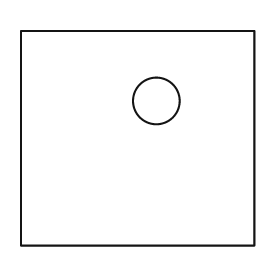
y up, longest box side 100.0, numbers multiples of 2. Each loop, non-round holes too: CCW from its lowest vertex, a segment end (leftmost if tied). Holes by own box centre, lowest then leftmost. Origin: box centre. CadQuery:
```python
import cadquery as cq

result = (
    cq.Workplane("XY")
    .moveTo(-50.0, -46.0)
    .lineTo(50.0, -46.0)
    .lineTo(50.0, 46.0)
    .lineTo(-50.0, 46.0)
    .close()
    .moveTo(8.0, 16.0)
    .circle(10.0)
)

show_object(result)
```